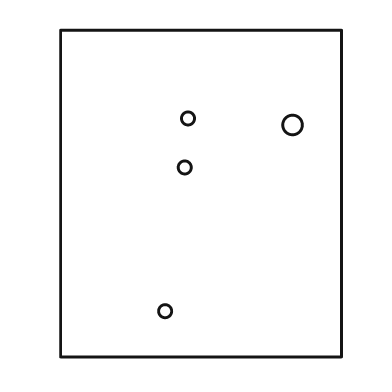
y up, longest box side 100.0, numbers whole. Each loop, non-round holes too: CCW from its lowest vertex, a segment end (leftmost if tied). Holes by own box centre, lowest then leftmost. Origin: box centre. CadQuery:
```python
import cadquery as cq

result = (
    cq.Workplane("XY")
    .moveTo(-43.0, -50.0)
    .lineTo(43.0, -50.0)
    .lineTo(43.0, 50.0)
    .lineTo(-43.0, 50.0)
    .close()
    .moveTo(-11.0, -36.0)
    .circle(2.0)
    .moveTo(-5.0, 8.0)
    .circle(2.0)
    .moveTo(28.0, 21.0)
    .circle(3.0)
    .moveTo(-4.0, 23.0)
    .circle(2.0)
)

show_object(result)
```